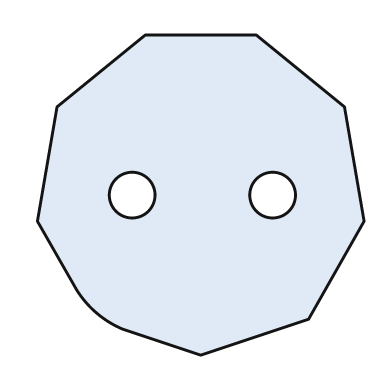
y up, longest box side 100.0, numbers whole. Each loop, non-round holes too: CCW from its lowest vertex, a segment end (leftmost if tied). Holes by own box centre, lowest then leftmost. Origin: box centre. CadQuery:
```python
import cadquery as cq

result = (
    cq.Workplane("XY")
    .moveTo(0.0, -49.0)
    .lineTo(33.0, -38.0)
    .lineTo(50.0, -8.0)
    .lineTo(44.0, 27.0)
    .lineTo(17.0, 49.0)
    .lineTo(-17.0, 49.0)
    .lineTo(-44.0, 27.0)
    .lineTo(-50.0, -8.0)
    .lineTo(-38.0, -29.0)
    .threePointArc((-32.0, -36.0), (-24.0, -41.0))
    .close()
    .moveTo(-21.0, 0.0)
    .circle(7.0)
    .moveTo(22.0, 0.0)
    .circle(7.0)
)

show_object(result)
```